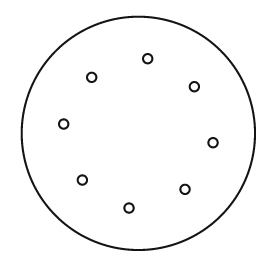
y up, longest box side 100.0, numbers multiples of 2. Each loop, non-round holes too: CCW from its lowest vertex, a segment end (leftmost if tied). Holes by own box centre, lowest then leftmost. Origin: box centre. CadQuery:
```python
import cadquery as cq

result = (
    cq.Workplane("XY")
    .moveTo(0.0, 0.0)
    .circle(50.0)
    .moveTo(-4.0, -32.0)
    .circle(2.0)
    .moveTo(20.0, -24.0)
    .circle(2.0)
    .moveTo(-24.0, -20.0)
    .circle(2.0)
    .moveTo(32.0, -4.0)
    .circle(2.0)
    .moveTo(-32.0, 4.0)
    .circle(2.0)
    .moveTo(24.0, 20.0)
    .circle(2.0)
    .moveTo(-20.0, 24.0)
    .circle(2.0)
    .moveTo(4.0, 32.0)
    .circle(2.0)
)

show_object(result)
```